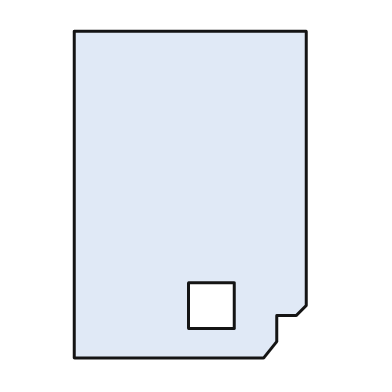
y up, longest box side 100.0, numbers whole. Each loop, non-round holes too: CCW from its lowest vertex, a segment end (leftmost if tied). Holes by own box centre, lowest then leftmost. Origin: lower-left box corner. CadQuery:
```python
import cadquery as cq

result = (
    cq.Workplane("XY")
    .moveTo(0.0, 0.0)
    .lineTo(58.0, 0.0)
    .lineTo(62.0, 5.0)
    .lineTo(62.0, 13.0)
    .lineTo(68.0, 13.0)
    .lineTo(71.0, 16.0)
    .lineTo(71.0, 100.0)
    .lineTo(0.0, 100.0)
    .close()
    .moveTo(35.0, 9.0)
    .lineTo(49.0, 9.0)
    .lineTo(49.0, 23.0)
    .lineTo(35.0, 23.0)
    .close()
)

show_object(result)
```